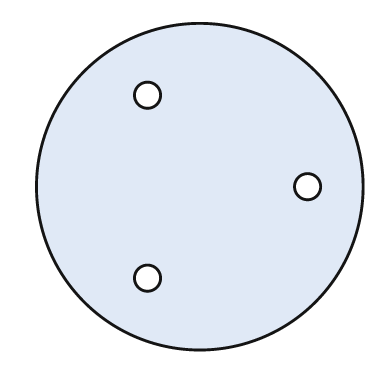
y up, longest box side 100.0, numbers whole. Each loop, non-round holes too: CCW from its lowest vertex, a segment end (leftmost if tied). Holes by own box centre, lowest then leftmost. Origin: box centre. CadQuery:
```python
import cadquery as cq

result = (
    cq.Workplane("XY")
    .moveTo(0.0, 0.0)
    .circle(50.0)
    .moveTo(-16.0, -28.0)
    .circle(4.0)
    .moveTo(33.0, 0.0)
    .circle(4.0)
    .moveTo(-16.0, 28.0)
    .circle(4.0)
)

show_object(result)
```